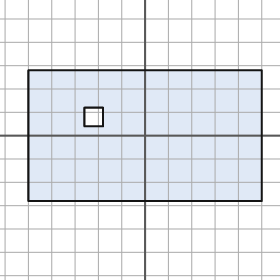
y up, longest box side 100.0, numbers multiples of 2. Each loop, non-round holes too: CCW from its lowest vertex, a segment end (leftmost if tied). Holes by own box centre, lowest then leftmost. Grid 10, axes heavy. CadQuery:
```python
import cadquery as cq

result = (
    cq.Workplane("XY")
    .moveTo(-50.0, -28.0)
    .lineTo(50.0, -28.0)
    .lineTo(50.0, 28.0)
    .lineTo(-50.0, 28.0)
    .close()
    .moveTo(-26.0, 4.0)
    .lineTo(-18.0, 4.0)
    .lineTo(-18.0, 12.0)
    .lineTo(-26.0, 12.0)
    .close()
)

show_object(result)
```